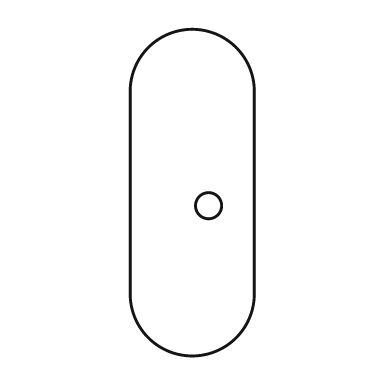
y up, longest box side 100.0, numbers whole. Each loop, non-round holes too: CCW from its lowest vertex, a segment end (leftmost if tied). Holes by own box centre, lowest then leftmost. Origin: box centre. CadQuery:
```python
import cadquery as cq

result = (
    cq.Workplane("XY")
    .moveTo(-19.0, -31.0)
    .threePointArc((0.0, -50.0), (19.0, -31.0))
    .lineTo(19.0, 31.0)
    .threePointArc((0.0, 50.0), (-19.0, 31.0))
    .close()
    .moveTo(5.0, -4.0)
    .circle(4.0)
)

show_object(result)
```